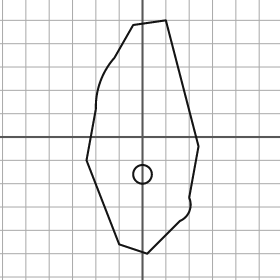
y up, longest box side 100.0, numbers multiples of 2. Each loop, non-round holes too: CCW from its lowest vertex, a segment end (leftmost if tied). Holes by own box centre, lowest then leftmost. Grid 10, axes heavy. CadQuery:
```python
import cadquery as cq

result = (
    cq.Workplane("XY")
    .moveTo(2.0, -50.0)
    .lineTo(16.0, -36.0)
    .threePointArc((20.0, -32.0), (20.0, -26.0))
    .lineTo(24.0, -4.0)
    .lineTo(10.0, 50.0)
    .lineTo(-4.0, 48.0)
    .lineTo(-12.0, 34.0)
    .threePointArc((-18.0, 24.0), (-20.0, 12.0))
    .lineTo(-24.0, -10.0)
    .lineTo(-10.0, -46.0)
    .close()
    .moveTo(0.0, -16.0)
    .circle(4.0)
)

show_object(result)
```